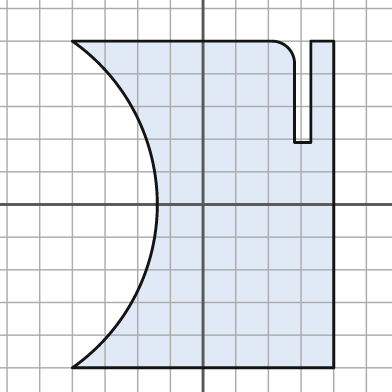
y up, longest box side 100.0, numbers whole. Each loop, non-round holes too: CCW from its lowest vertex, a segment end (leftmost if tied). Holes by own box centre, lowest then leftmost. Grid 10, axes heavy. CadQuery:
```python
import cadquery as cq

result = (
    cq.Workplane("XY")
    .moveTo(-40.0, -50.0)
    .lineTo(40.0, -50.0)
    .lineTo(40.0, 50.0)
    .lineTo(33.0, 50.0)
    .lineTo(33.0, 19.0)
    .lineTo(28.0, 19.0)
    .lineTo(28.0, 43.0)
    .threePointArc((26.0, 48.0), (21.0, 50.0))
    .lineTo(-40.0, 50.0)
    .threePointArc((-14.0, 0.0), (-40.0, -50.0))
    .close()
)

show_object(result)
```